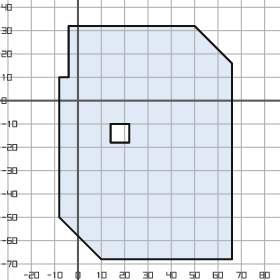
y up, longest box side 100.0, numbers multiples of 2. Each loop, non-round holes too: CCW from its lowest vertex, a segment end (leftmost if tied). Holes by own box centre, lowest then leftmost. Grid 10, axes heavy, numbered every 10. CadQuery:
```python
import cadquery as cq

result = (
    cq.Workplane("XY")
    .moveTo(10.0, -68.0)
    .lineTo(66.0, -68.0)
    .lineTo(66.0, 16.0)
    .lineTo(50.0, 32.0)
    .lineTo(-4.0, 32.0)
    .lineTo(-4.0, 10.0)
    .lineTo(-8.0, 10.0)
    .lineTo(-8.0, -50.0)
    .close()
    .moveTo(14.0, -18.0)
    .lineTo(22.0, -18.0)
    .lineTo(22.0, -10.0)
    .lineTo(14.0, -10.0)
    .close()
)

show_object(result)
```